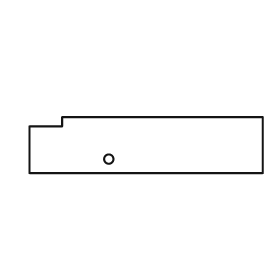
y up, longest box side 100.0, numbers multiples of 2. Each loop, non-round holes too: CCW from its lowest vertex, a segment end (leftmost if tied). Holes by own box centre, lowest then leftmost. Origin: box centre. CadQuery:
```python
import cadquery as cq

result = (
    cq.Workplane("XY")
    .moveTo(-50.0, -12.0)
    .lineTo(50.0, -12.0)
    .lineTo(50.0, 12.0)
    .lineTo(-36.0, 12.0)
    .lineTo(-36.0, 8.0)
    .lineTo(-50.0, 8.0)
    .close()
    .moveTo(-16.0, -6.0)
    .circle(2.0)
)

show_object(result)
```